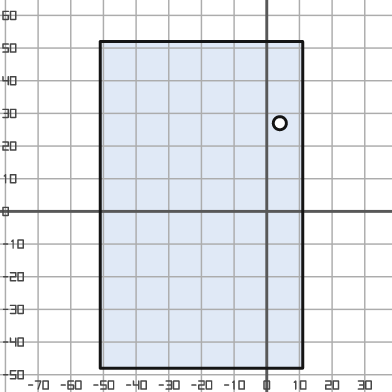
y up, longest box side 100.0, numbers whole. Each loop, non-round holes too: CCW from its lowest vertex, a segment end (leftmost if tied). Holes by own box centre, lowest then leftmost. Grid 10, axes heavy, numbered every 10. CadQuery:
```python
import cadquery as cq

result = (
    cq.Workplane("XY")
    .moveTo(-51.0, -48.0)
    .lineTo(11.0, -48.0)
    .lineTo(11.0, 52.0)
    .lineTo(-51.0, 52.0)
    .close()
    .moveTo(4.0, 27.0)
    .circle(2.0)
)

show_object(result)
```